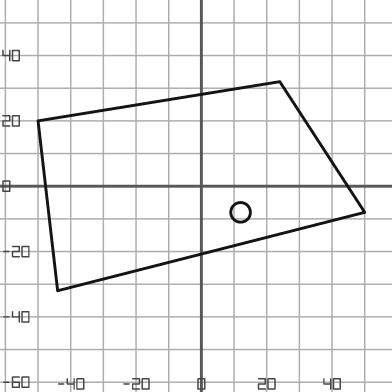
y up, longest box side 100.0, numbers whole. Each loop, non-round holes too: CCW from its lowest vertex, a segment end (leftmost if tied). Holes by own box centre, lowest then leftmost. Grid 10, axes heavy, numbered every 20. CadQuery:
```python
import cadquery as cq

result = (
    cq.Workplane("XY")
    .moveTo(-44.0, -32.0)
    .lineTo(50.0, -8.0)
    .lineTo(24.0, 32.0)
    .lineTo(-50.0, 20.0)
    .close()
    .moveTo(12.0, -8.0)
    .circle(3.0)
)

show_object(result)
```